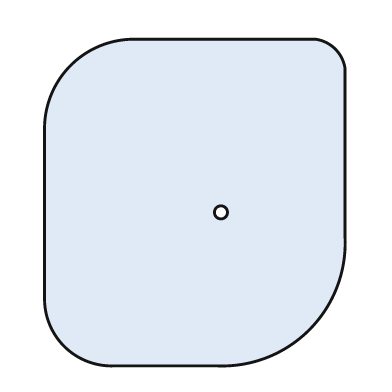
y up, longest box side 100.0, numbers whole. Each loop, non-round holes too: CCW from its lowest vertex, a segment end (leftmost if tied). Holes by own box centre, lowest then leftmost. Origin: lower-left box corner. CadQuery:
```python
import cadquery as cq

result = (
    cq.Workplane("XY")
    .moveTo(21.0, 0.0)
    .lineTo(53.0, 0.0)
    .threePointArc((81.0, 11.0), (92.0, 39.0))
    .lineTo(92.0, 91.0)
    .threePointArc((89.0, 97.0), (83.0, 100.0))
    .lineTo(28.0, 100.0)
    .threePointArc((8.0, 92.0), (0.0, 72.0))
    .lineTo(0.0, 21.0)
    .threePointArc((6.0, 6.0), (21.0, 0.0))
    .close()
    .moveTo(54.0, 47.0)
    .circle(2.0)
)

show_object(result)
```